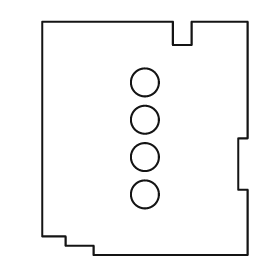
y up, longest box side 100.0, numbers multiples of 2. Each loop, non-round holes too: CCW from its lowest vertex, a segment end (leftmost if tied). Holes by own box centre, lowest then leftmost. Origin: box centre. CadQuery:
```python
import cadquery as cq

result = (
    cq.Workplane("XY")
    .moveTo(-22.0, -50.0)
    .lineTo(44.0, -50.0)
    .lineTo(44.0, -22.0)
    .lineTo(40.0, -22.0)
    .lineTo(40.0, 0.0)
    .lineTo(44.0, 0.0)
    .lineTo(44.0, 50.0)
    .lineTo(20.0, 50.0)
    .lineTo(20.0, 40.0)
    .lineTo(12.0, 40.0)
    .lineTo(12.0, 50.0)
    .lineTo(-44.0, 50.0)
    .lineTo(-44.0, -42.0)
    .lineTo(-34.0, -42.0)
    .lineTo(-34.0, -46.0)
    .lineTo(-22.0, -46.0)
    .close()
    .moveTo(0.0, -24.0)
    .circle(6.0)
    .moveTo(0.0, -8.0)
    .circle(6.0)
    .moveTo(0.0, 8.0)
    .circle(6.0)
    .moveTo(0.0, 24.0)
    .circle(6.0)
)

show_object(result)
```